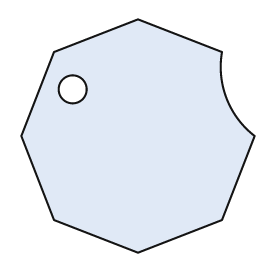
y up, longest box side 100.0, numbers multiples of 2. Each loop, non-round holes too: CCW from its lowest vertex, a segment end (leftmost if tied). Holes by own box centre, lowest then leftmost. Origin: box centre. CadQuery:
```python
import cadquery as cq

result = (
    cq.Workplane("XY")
    .moveTo(0.0, -50.0)
    .lineTo(36.0, -36.0)
    .lineTo(50.0, 0.0)
    .threePointArc((38.0, 16.0), (36.0, 36.0))
    .lineTo(0.0, 50.0)
    .lineTo(-36.0, 36.0)
    .lineTo(-50.0, 0.0)
    .lineTo(-36.0, -36.0)
    .close()
    .moveTo(-28.0, 20.0)
    .circle(6.0)
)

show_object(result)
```